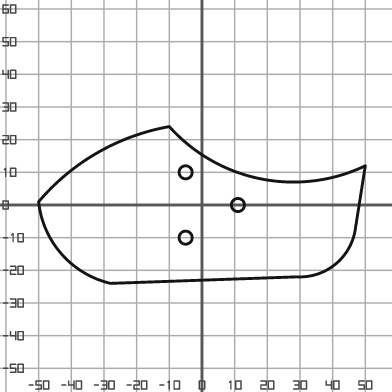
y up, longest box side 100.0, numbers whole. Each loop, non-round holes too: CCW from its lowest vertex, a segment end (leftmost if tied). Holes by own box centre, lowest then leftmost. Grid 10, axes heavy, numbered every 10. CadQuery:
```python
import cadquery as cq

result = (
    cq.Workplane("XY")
    .moveTo(-28.0, -24.0)
    .lineTo(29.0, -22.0)
    .threePointArc((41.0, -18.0), (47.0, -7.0))
    .lineTo(50.0, 12.0)
    .threePointArc((18.0, 8.0), (-10.0, 24.0))
    .threePointArc((-32.0, 16.0), (-50.0, 1.0))
    .threePointArc((-43.0, -15.0), (-28.0, -24.0))
    .close()
    .moveTo(-5.0, -10.0)
    .circle(2.0)
    .moveTo(11.0, 0.0)
    .circle(2.0)
    .moveTo(-5.0, 10.0)
    .circle(2.0)
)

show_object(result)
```